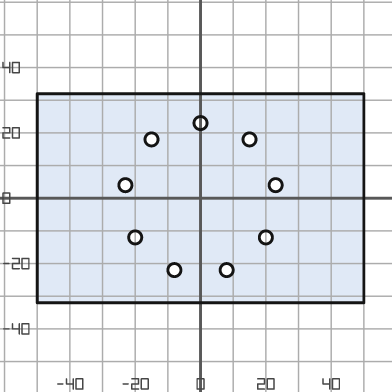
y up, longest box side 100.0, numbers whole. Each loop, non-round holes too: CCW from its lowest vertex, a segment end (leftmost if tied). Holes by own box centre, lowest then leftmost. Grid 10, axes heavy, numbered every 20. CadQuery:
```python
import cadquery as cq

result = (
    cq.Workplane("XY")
    .moveTo(-50.0, -32.0)
    .lineTo(50.0, -32.0)
    .lineTo(50.0, 32.0)
    .lineTo(-50.0, 32.0)
    .close()
    .moveTo(-8.0, -22.0)
    .circle(2.0)
    .moveTo(8.0, -22.0)
    .circle(2.0)
    .moveTo(-20.0, -12.0)
    .circle(2.0)
    .moveTo(20.0, -12.0)
    .circle(2.0)
    .moveTo(-23.0, 4.0)
    .circle(2.0)
    .moveTo(23.0, 4.0)
    .circle(2.0)
    .moveTo(-15.0, 18.0)
    .circle(2.0)
    .moveTo(15.0, 18.0)
    .circle(2.0)
    .moveTo(0.0, 23.0)
    .circle(2.0)
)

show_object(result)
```